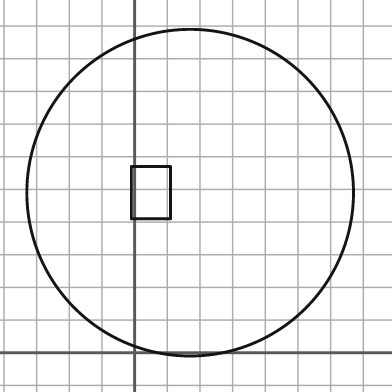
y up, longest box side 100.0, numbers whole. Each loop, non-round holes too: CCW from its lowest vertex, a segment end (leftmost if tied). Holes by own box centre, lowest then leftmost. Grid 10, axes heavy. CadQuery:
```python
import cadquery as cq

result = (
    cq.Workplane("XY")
    .moveTo(17.0, 49.0)
    .circle(50.0)
    .moveTo(-1.0, 41.0)
    .lineTo(11.0, 41.0)
    .lineTo(11.0, 57.0)
    .lineTo(-1.0, 57.0)
    .close()
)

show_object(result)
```